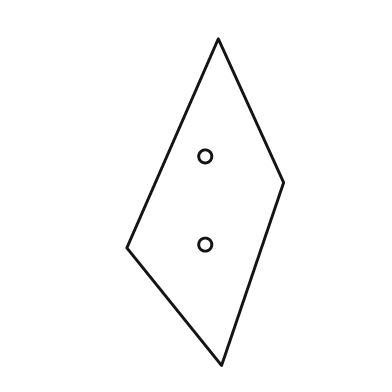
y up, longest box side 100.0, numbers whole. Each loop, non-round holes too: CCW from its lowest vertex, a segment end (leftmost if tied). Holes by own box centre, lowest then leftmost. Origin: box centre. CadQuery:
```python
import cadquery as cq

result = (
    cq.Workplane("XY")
    .moveTo(5.0, -50.0)
    .lineTo(24.0, 6.0)
    .lineTo(4.0, 50.0)
    .lineTo(-24.0, -14.0)
    .close()
    .moveTo(0.0, -13.0)
    .circle(2.0)
    .moveTo(0.0, 14.0)
    .circle(2.0)
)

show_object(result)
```